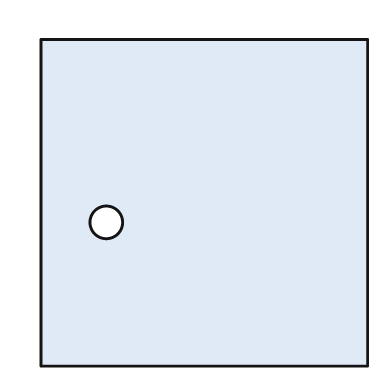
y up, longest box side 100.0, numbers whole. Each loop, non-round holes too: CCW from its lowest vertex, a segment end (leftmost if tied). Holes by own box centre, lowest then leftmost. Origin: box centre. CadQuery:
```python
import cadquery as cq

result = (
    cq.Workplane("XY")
    .moveTo(-50.0, -50.0)
    .lineTo(50.0, -50.0)
    .lineTo(50.0, 50.0)
    .lineTo(-50.0, 50.0)
    .close()
    .moveTo(-30.0, -6.0)
    .circle(5.0)
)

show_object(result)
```